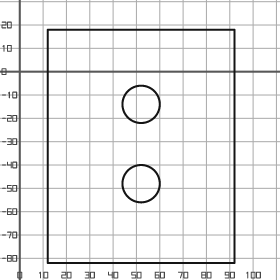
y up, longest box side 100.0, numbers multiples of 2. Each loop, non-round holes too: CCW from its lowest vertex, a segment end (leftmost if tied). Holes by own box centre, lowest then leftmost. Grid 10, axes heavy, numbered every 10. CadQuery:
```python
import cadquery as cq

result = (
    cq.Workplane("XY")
    .moveTo(12.0, -82.0)
    .lineTo(92.0, -82.0)
    .lineTo(92.0, 18.0)
    .lineTo(12.0, 18.0)
    .close()
    .moveTo(52.0, -48.0)
    .circle(8.0)
    .moveTo(52.0, -14.0)
    .circle(8.0)
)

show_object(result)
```